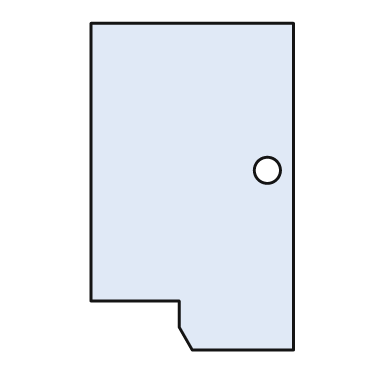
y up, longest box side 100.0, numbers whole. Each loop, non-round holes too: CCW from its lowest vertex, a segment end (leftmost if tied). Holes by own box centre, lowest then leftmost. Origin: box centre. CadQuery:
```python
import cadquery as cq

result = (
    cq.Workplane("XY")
    .moveTo(0.0, -50.0)
    .lineTo(31.0, -50.0)
    .lineTo(31.0, 50.0)
    .lineTo(-31.0, 50.0)
    .lineTo(-31.0, -35.0)
    .lineTo(-4.0, -35.0)
    .lineTo(-4.0, -43.0)
    .close()
    .moveTo(23.0, 5.0)
    .circle(4.0)
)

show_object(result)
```